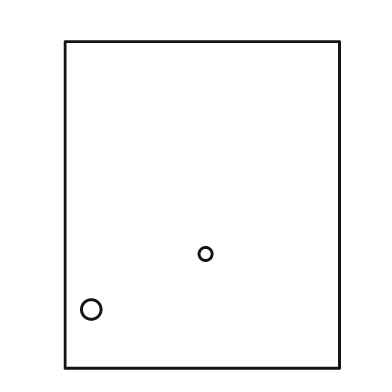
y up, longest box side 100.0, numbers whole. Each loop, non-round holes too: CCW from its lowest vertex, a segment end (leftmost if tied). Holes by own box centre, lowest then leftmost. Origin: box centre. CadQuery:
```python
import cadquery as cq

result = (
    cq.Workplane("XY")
    .moveTo(-42.0, -50.0)
    .lineTo(42.0, -50.0)
    .lineTo(42.0, 50.0)
    .lineTo(-42.0, 50.0)
    .close()
    .moveTo(-34.0, -32.0)
    .circle(3.0)
    .moveTo(1.0, -15.0)
    .circle(2.0)
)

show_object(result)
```